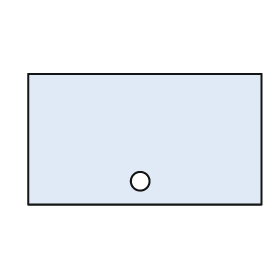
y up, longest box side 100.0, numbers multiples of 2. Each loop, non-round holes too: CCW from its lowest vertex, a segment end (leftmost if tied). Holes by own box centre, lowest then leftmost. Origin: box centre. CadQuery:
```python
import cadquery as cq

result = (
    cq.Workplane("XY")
    .moveTo(-50.0, -28.0)
    .lineTo(50.0, -28.0)
    .lineTo(50.0, 28.0)
    .lineTo(-50.0, 28.0)
    .close()
    .moveTo(-2.0, -18.0)
    .circle(4.0)
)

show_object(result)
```